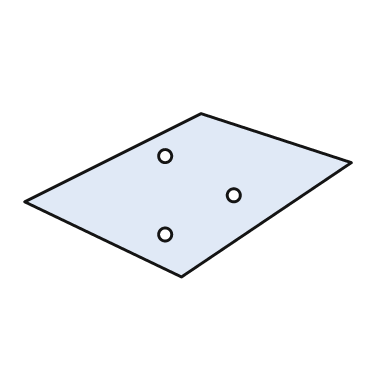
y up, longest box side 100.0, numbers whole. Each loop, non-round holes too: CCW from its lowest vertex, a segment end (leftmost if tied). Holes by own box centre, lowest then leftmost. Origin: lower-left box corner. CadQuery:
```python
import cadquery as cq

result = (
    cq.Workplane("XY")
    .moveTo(48.0, 0.0)
    .lineTo(100.0, 35.0)
    .lineTo(54.0, 50.0)
    .lineTo(0.0, 23.0)
    .close()
    .moveTo(43.0, 13.0)
    .circle(2.0)
    .moveTo(64.0, 25.0)
    .circle(2.0)
    .moveTo(43.0, 37.0)
    .circle(2.0)
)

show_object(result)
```